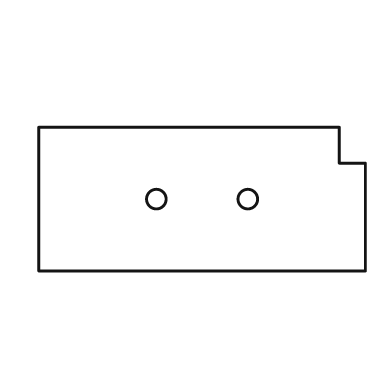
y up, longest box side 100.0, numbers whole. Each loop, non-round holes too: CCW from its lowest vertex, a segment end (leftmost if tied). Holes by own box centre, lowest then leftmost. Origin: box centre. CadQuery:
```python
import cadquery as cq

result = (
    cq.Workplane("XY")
    .moveTo(-50.0, -22.0)
    .lineTo(50.0, -22.0)
    .lineTo(50.0, 11.0)
    .lineTo(42.0, 11.0)
    .lineTo(42.0, 22.0)
    .lineTo(-50.0, 22.0)
    .close()
    .moveTo(-14.0, 0.0)
    .circle(3.0)
    .moveTo(14.0, 0.0)
    .circle(3.0)
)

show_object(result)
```